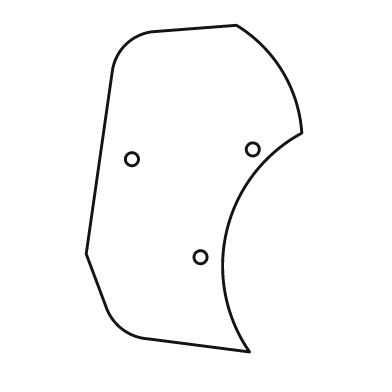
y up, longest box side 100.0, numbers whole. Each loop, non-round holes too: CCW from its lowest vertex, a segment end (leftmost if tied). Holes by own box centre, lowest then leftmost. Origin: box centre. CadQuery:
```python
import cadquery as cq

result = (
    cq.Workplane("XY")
    .moveTo(17.0, -50.0)
    .threePointArc((10.0, -13.0), (33.0, 17.0))
    .threePointArc((27.0, 36.0), (13.0, 50.0))
    .lineTo(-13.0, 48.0)
    .threePointArc((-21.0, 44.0), (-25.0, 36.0))
    .lineTo(-33.0, -20.0)
    .lineTo(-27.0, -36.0)
    .threePointArc((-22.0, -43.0), (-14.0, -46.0))
    .close()
    .moveTo(2.0, -21.0)
    .circle(2.0)
    .moveTo(-19.0, 9.0)
    .circle(2.0)
    .moveTo(18.0, 12.0)
    .circle(2.0)
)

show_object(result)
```